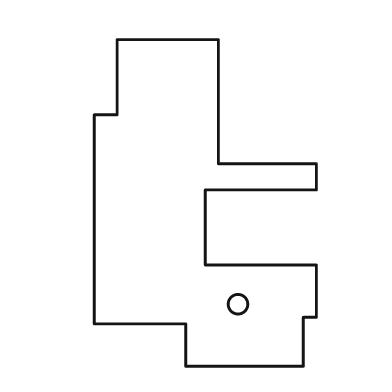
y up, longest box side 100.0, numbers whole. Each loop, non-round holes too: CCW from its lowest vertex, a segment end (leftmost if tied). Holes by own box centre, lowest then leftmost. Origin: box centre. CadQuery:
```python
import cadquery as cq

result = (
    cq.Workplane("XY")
    .moveTo(-6.0, -50.0)
    .lineTo(30.0, -50.0)
    .lineTo(30.0, -35.0)
    .lineTo(34.0, -35.0)
    .lineTo(34.0, -19.0)
    .lineTo(0.0, -19.0)
    .lineTo(0.0, 4.0)
    .lineTo(34.0, 4.0)
    .lineTo(34.0, 12.0)
    .lineTo(4.0, 12.0)
    .lineTo(4.0, 50.0)
    .lineTo(-27.0, 50.0)
    .lineTo(-27.0, 27.0)
    .lineTo(-34.0, 27.0)
    .lineTo(-34.0, -37.0)
    .lineTo(-6.0, -37.0)
    .close()
    .moveTo(10.0, -31.0)
    .circle(3.0)
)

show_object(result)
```